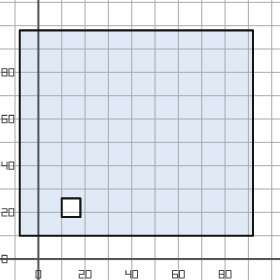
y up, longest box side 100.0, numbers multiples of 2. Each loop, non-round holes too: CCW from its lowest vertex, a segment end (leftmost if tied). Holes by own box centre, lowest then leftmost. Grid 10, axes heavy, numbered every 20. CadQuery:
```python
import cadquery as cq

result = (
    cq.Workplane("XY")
    .moveTo(-8.0, 10.0)
    .lineTo(92.0, 10.0)
    .lineTo(92.0, 98.0)
    .lineTo(-8.0, 98.0)
    .close()
    .moveTo(10.0, 18.0)
    .lineTo(18.0, 18.0)
    .lineTo(18.0, 26.0)
    .lineTo(10.0, 26.0)
    .close()
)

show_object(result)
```